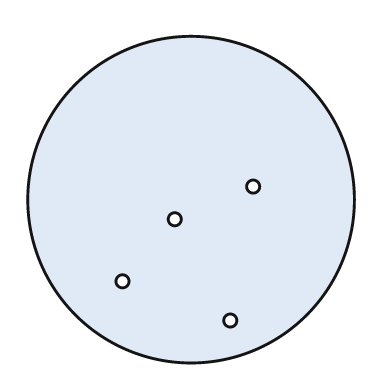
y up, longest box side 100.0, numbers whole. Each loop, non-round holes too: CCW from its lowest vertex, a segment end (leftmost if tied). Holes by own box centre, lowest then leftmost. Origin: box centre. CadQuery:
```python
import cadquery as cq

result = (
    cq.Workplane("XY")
    .moveTo(0.0, 0.0)
    .circle(50.0)
    .moveTo(12.0, -37.0)
    .circle(2.0)
    .moveTo(-21.0, -25.0)
    .circle(2.0)
    .moveTo(-5.0, -6.0)
    .circle(2.0)
    .moveTo(19.0, 4.0)
    .circle(2.0)
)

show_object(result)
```